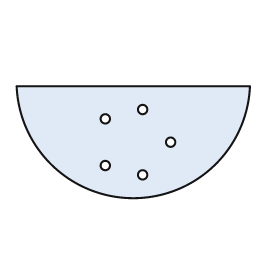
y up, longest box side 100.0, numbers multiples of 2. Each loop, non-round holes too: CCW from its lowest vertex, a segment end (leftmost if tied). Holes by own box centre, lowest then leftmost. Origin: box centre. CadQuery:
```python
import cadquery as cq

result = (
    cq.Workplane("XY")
    .moveTo(-50.0, 24.0)
    .threePointArc((0.0, -24.0), (50.0, 24.0))
    .close()
    .moveTo(4.0, -14.0)
    .circle(2.0)
    .moveTo(-12.0, -10.0)
    .circle(2.0)
    .moveTo(16.0, 0.0)
    .circle(2.0)
    .moveTo(-12.0, 10.0)
    .circle(2.0)
    .moveTo(4.0, 14.0)
    .circle(2.0)
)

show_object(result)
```